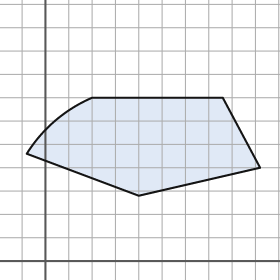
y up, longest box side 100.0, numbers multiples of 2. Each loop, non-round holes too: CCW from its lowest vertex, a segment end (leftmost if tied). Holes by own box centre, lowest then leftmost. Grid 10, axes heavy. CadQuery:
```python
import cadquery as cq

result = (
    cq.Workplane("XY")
    .moveTo(40.0, 28.0)
    .lineTo(92.0, 40.0)
    .lineTo(76.0, 70.0)
    .lineTo(20.0, 70.0)
    .threePointArc((4.0, 60.0), (-8.0, 46.0))
    .close()
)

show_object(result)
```